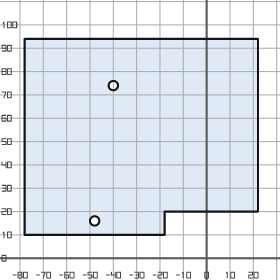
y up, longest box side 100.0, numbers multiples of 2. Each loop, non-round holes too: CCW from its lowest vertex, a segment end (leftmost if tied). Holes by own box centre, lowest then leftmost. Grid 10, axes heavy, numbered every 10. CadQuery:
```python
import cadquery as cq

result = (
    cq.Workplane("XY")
    .moveTo(-78.0, 10.0)
    .lineTo(-18.0, 10.0)
    .lineTo(-18.0, 20.0)
    .lineTo(22.0, 20.0)
    .lineTo(22.0, 94.0)
    .lineTo(-78.0, 94.0)
    .close()
    .moveTo(-48.0, 16.0)
    .circle(2.0)
    .moveTo(-40.0, 74.0)
    .circle(2.0)
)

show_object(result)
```